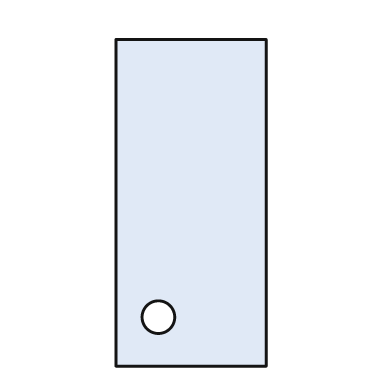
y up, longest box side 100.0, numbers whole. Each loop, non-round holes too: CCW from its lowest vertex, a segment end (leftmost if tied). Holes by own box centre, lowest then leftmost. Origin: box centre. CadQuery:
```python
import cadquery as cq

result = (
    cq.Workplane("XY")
    .moveTo(-23.0, -50.0)
    .lineTo(23.0, -50.0)
    .lineTo(23.0, 50.0)
    .lineTo(-23.0, 50.0)
    .close()
    .moveTo(-10.0, -35.0)
    .circle(5.0)
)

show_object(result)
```